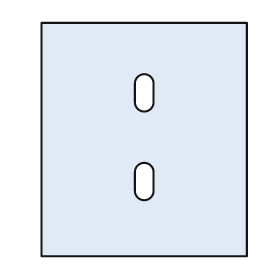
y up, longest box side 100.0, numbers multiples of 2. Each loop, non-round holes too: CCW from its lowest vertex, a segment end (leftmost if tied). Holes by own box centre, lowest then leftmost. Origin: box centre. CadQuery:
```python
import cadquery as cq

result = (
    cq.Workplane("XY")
    .moveTo(-44.0, -50.0)
    .lineTo(44.0, -50.0)
    .lineTo(44.0, 50.0)
    .lineTo(-44.0, 50.0)
    .close()
    .moveTo(-4.0, -22.0)
    .threePointArc((0.0, -26.0), (4.0, -22.0))
    .lineTo(4.0, -14.0)
    .threePointArc((0.0, -10.0), (-4.0, -14.0))
    .close()
    .moveTo(-4.0, 16.0)
    .threePointArc((0.0, 12.0), (4.0, 16.0))
    .lineTo(4.0, 24.0)
    .threePointArc((0.0, 28.0), (-4.0, 24.0))
    .close()
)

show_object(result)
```